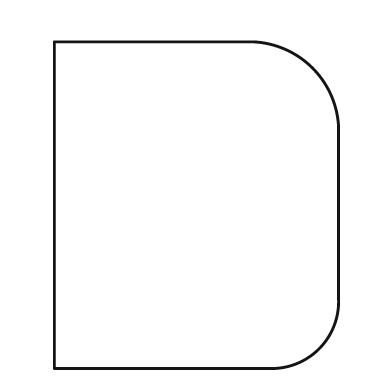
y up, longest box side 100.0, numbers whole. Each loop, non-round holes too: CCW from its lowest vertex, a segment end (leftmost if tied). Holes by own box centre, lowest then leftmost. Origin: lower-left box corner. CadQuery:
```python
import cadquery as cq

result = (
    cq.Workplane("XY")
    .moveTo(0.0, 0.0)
    .lineTo(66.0, 0.0)
    .threePointArc((81.0, 6.0), (87.0, 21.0))
    .lineTo(87.0, 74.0)
    .threePointArc((79.0, 92.0), (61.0, 100.0))
    .lineTo(0.0, 100.0)
    .close()
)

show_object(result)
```